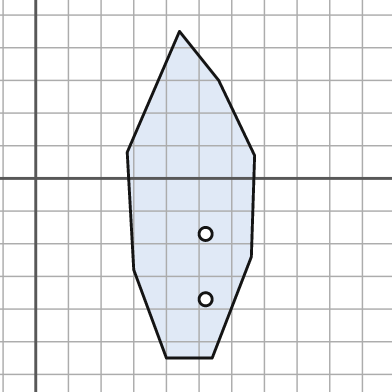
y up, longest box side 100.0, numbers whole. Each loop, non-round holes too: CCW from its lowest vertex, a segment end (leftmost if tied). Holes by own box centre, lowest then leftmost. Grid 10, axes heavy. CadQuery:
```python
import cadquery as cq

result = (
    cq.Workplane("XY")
    .moveTo(40.0, -55.0)
    .lineTo(54.0, -55.0)
    .lineTo(66.0, -24.0)
    .lineTo(67.0, 7.0)
    .lineTo(56.0, 30.0)
    .lineTo(44.0, 45.0)
    .lineTo(28.0, 8.0)
    .lineTo(30.0, -28.0)
    .close()
    .moveTo(52.0, -37.0)
    .circle(2.0)
    .moveTo(52.0, -17.0)
    .circle(2.0)
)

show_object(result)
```